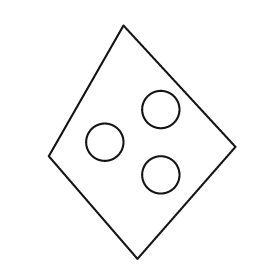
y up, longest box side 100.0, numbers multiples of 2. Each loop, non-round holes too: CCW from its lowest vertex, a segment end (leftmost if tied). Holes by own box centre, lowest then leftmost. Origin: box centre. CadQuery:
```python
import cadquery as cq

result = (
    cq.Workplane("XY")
    .moveTo(-2.0, -50.0)
    .lineTo(40.0, -2.0)
    .lineTo(-8.0, 50.0)
    .lineTo(-40.0, -6.0)
    .close()
    .moveTo(8.0, -14.0)
    .circle(8.0)
    .moveTo(-16.0, 0.0)
    .circle(8.0)
    .moveTo(8.0, 14.0)
    .circle(8.0)
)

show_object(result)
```